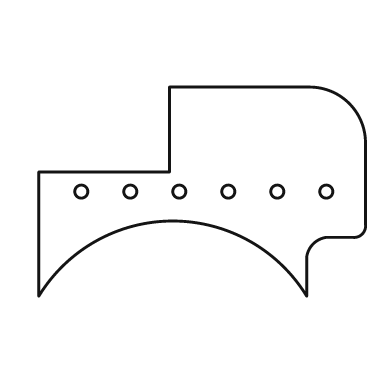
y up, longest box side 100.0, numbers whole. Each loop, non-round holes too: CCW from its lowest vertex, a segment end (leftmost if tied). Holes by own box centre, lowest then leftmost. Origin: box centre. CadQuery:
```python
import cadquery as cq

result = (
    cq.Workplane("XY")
    .moveTo(-50.0, -32.0)
    .threePointArc((-9.0, -9.0), (32.0, -32.0))
    .lineTo(32.0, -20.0)
    .threePointArc((34.0, -16.0), (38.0, -14.0))
    .lineTo(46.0, -14.0)
    .threePointArc((49.0, -13.0), (50.0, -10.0))
    .lineTo(50.0, 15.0)
    .threePointArc((45.0, 27.0), (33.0, 32.0))
    .lineTo(-10.0, 32.0)
    .lineTo(-10.0, 6.0)
    .lineTo(-50.0, 6.0)
    .close()
    .moveTo(-37.0, 0.0)
    .circle(2.0)
    .moveTo(-22.0, 0.0)
    .circle(2.0)
    .moveTo(-7.0, 0.0)
    .circle(2.0)
    .moveTo(8.0, 0.0)
    .circle(2.0)
    .moveTo(23.0, 0.0)
    .circle(2.0)
    .moveTo(38.0, 0.0)
    .circle(2.0)
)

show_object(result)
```